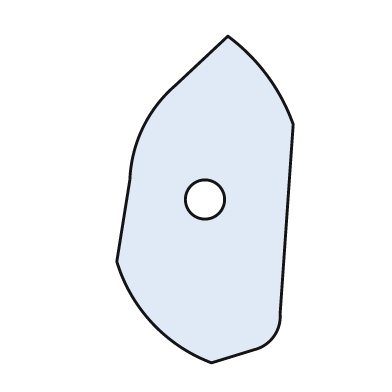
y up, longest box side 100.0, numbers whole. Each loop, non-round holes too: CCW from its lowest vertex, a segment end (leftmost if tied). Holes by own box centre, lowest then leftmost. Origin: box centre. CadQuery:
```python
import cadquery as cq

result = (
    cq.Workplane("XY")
    .moveTo(2.0, -50.0)
    .lineTo(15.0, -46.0)
    .threePointArc((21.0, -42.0), (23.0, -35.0))
    .lineTo(27.0, 23.0)
    .threePointArc((19.0, 38.0), (7.0, 50.0))
    .lineTo(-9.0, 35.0)
    .threePointArc((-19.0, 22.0), (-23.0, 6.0))
    .lineTo(-27.0, -19.0)
    .threePointArc((-16.0, -38.0), (2.0, -50.0))
    .close()
    .moveTo(0.0, 0.0)
    .circle(6.0)
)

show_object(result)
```